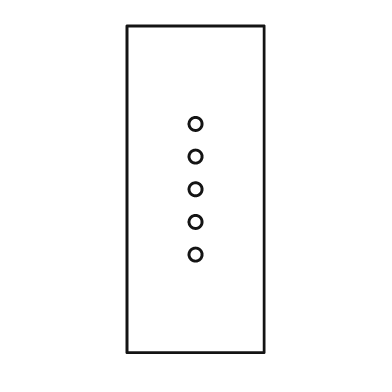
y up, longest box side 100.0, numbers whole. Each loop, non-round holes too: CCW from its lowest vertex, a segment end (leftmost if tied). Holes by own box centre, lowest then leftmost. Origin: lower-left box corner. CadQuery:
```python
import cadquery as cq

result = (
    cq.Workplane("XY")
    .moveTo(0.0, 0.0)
    .lineTo(42.0, 0.0)
    .lineTo(42.0, 100.0)
    .lineTo(0.0, 100.0)
    .close()
    .moveTo(21.0, 30.0)
    .circle(2.0)
    .moveTo(21.0, 40.0)
    .circle(2.0)
    .moveTo(21.0, 50.0)
    .circle(2.0)
    .moveTo(21.0, 60.0)
    .circle(2.0)
    .moveTo(21.0, 70.0)
    .circle(2.0)
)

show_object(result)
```